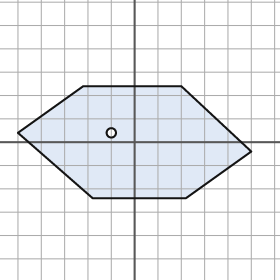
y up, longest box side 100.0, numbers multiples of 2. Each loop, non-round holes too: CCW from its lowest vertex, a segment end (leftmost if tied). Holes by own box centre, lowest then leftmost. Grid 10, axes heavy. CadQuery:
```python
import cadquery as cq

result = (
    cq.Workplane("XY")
    .moveTo(-18.0, -24.0)
    .lineTo(22.0, -24.0)
    .lineTo(50.0, -4.0)
    .lineTo(20.0, 24.0)
    .lineTo(-22.0, 24.0)
    .lineTo(-50.0, 4.0)
    .close()
    .moveTo(-10.0, 4.0)
    .circle(2.0)
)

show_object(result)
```